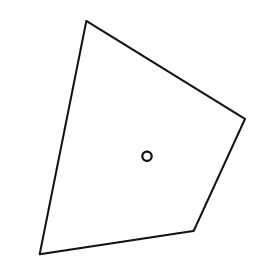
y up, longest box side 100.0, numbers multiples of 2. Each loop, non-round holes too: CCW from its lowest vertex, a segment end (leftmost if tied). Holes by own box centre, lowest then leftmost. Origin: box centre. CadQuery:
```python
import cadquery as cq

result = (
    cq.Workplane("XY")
    .moveTo(-44.0, -50.0)
    .lineTo(22.0, -40.0)
    .lineTo(44.0, 8.0)
    .lineTo(-24.0, 50.0)
    .close()
    .moveTo(2.0, -8.0)
    .circle(2.0)
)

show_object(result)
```